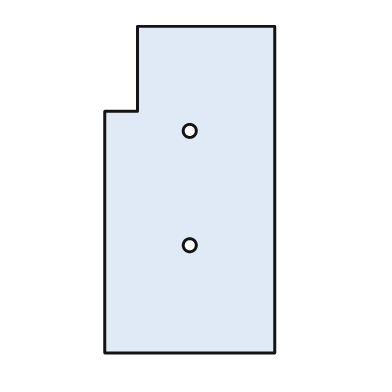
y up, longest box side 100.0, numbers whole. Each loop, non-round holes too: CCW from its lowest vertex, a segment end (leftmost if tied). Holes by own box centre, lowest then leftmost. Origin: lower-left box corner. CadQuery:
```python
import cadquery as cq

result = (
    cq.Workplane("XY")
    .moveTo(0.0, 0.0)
    .lineTo(52.0, 0.0)
    .lineTo(52.0, 100.0)
    .lineTo(10.0, 100.0)
    .lineTo(10.0, 74.0)
    .lineTo(0.0, 74.0)
    .close()
    .moveTo(26.0, 33.0)
    .circle(2.0)
    .moveTo(26.0, 68.0)
    .circle(2.0)
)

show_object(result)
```